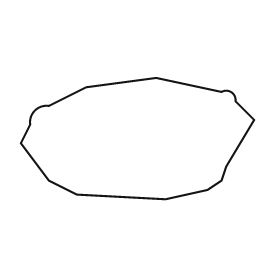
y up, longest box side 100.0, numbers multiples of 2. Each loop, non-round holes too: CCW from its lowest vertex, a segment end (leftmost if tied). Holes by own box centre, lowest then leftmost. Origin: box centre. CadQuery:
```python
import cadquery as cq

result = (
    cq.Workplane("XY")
    .moveTo(12.0, -26.0)
    .lineTo(30.0, -22.0)
    .lineTo(36.0, -18.0)
    .lineTo(38.0, -12.0)
    .lineTo(50.0, 8.0)
    .lineTo(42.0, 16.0)
    .threePointArc((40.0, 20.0), (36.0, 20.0))
    .lineTo(8.0, 26.0)
    .lineTo(-22.0, 22.0)
    .lineTo(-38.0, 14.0)
    .threePointArc((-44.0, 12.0), (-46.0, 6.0))
    .lineTo(-50.0, -2.0)
    .lineTo(-38.0, -18.0)
    .lineTo(-26.0, -24.0)
    .close()
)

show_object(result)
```